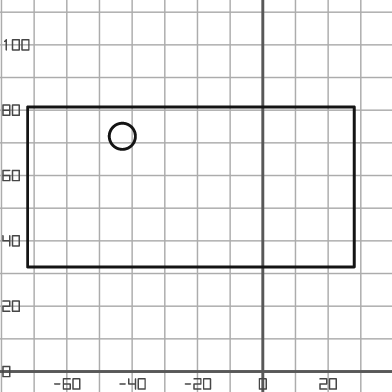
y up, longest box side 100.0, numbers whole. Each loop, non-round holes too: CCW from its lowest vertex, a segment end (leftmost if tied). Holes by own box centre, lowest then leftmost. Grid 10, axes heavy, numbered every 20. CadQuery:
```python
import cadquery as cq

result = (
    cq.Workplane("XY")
    .moveTo(-72.0, 32.0)
    .lineTo(28.0, 32.0)
    .lineTo(28.0, 81.0)
    .lineTo(-72.0, 81.0)
    .close()
    .moveTo(-43.0, 72.0)
    .circle(4.0)
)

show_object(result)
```